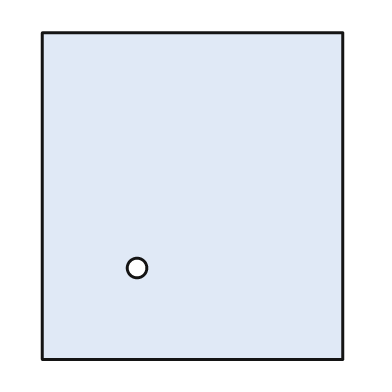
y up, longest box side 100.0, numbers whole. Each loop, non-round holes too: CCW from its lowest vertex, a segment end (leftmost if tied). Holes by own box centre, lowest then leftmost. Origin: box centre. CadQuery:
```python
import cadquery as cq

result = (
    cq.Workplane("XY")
    .moveTo(-46.0, -50.0)
    .lineTo(46.0, -50.0)
    .lineTo(46.0, 50.0)
    .lineTo(-46.0, 50.0)
    .close()
    .moveTo(-17.0, -22.0)
    .circle(3.0)
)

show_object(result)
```